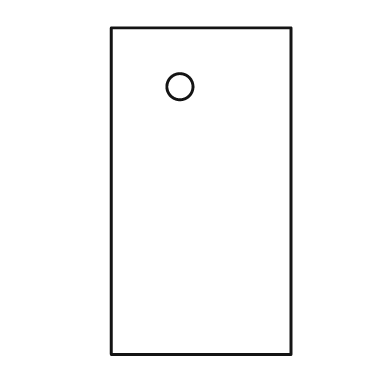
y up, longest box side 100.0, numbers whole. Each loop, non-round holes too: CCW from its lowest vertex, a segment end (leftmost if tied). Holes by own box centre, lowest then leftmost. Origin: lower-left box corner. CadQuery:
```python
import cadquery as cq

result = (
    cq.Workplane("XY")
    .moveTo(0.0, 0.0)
    .lineTo(55.0, 0.0)
    .lineTo(55.0, 100.0)
    .lineTo(0.0, 100.0)
    .close()
    .moveTo(21.0, 82.0)
    .circle(4.0)
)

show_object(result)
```